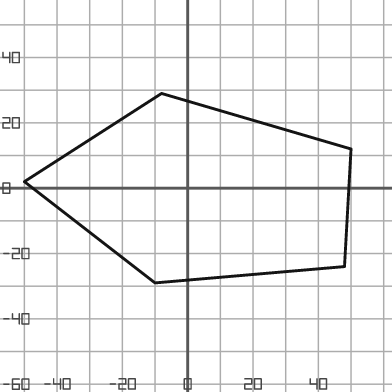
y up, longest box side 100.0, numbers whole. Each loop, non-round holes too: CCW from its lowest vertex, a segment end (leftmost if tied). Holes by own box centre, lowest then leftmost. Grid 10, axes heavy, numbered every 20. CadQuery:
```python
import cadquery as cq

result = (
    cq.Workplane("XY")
    .moveTo(-10.0, -29.0)
    .lineTo(48.0, -24.0)
    .lineTo(50.0, 12.0)
    .lineTo(-8.0, 29.0)
    .lineTo(-50.0, 2.0)
    .close()
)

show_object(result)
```